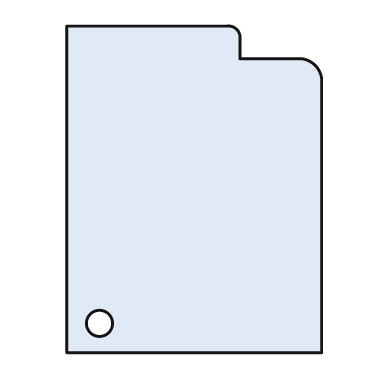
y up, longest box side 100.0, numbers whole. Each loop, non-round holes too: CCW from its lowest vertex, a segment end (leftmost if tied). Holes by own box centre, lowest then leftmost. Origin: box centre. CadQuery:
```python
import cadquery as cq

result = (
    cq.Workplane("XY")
    .moveTo(-39.0, -50.0)
    .lineTo(39.0, -50.0)
    .lineTo(39.0, 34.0)
    .threePointArc((37.0, 38.0), (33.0, 40.0))
    .lineTo(14.0, 40.0)
    .lineTo(14.0, 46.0)
    .threePointArc((13.0, 49.0), (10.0, 50.0))
    .lineTo(-39.0, 50.0)
    .close()
    .moveTo(-29.0, -41.0)
    .circle(4.0)
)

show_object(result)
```